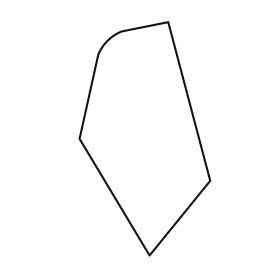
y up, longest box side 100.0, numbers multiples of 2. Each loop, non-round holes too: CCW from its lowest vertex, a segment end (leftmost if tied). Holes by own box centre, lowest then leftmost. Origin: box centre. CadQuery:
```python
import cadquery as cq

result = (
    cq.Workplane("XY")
    .moveTo(2.0, -50.0)
    .lineTo(28.0, -18.0)
    .lineTo(10.0, 50.0)
    .lineTo(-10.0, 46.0)
    .threePointArc((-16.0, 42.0), (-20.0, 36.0))
    .lineTo(-28.0, 0.0)
    .close()
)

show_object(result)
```